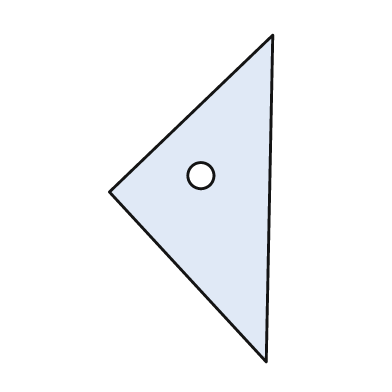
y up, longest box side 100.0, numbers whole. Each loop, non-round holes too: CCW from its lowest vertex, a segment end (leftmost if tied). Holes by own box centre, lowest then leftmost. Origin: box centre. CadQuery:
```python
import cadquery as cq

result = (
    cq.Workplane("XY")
    .moveTo(23.0, -50.0)
    .lineTo(25.0, 50.0)
    .lineTo(-25.0, 2.0)
    .close()
    .moveTo(3.0, 7.0)
    .circle(4.0)
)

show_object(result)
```